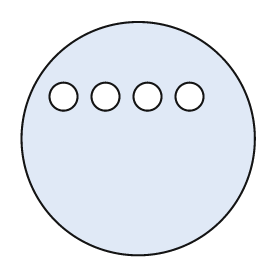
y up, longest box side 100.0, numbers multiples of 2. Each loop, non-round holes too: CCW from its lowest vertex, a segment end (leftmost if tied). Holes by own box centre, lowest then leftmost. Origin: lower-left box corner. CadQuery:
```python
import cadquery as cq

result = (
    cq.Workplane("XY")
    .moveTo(50.0, 50.0)
    .circle(50.0)
    .moveTo(18.0, 68.0)
    .circle(6.0)
    .moveTo(36.0, 68.0)
    .circle(6.0)
    .moveTo(54.0, 68.0)
    .circle(6.0)
    .moveTo(72.0, 68.0)
    .circle(6.0)
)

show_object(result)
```